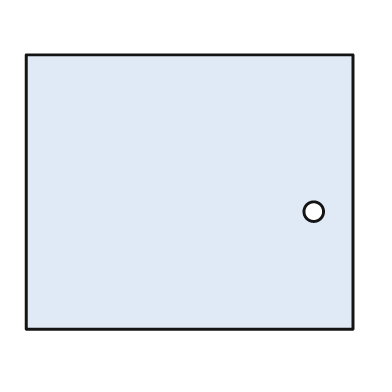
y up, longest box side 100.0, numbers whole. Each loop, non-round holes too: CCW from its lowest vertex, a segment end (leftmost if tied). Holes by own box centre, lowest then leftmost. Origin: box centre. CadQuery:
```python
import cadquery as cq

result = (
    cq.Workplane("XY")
    .moveTo(-50.0, -42.0)
    .lineTo(50.0, -42.0)
    .lineTo(50.0, 42.0)
    .lineTo(-50.0, 42.0)
    .close()
    .moveTo(38.0, -6.0)
    .circle(3.0)
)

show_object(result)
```